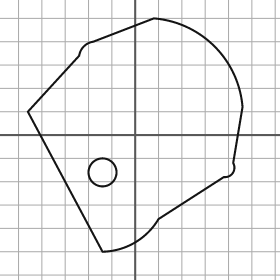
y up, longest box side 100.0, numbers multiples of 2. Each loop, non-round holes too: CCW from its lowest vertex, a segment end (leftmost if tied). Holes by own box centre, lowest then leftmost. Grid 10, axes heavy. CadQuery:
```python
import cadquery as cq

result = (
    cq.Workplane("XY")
    .moveTo(-14.0, -50.0)
    .threePointArc((0.0, -46.0), (10.0, -36.0))
    .lineTo(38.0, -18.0)
    .threePointArc((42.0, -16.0), (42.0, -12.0))
    .lineTo(46.0, 12.0)
    .threePointArc((34.0, 38.0), (8.0, 50.0))
    .lineTo(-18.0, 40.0)
    .threePointArc((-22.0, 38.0), (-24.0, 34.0))
    .lineTo(-46.0, 10.0)
    .close()
    .moveTo(-14.0, -16.0)
    .circle(6.0)
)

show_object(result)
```